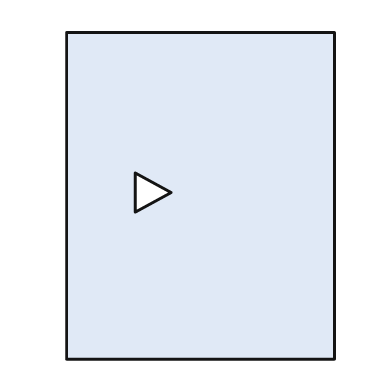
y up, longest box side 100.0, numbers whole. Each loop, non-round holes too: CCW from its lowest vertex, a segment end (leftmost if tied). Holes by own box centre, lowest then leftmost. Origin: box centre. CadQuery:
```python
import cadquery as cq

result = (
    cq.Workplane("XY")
    .moveTo(-41.0, -50.0)
    .lineTo(41.0, -50.0)
    .lineTo(41.0, 50.0)
    .lineTo(-41.0, 50.0)
    .close()
    .moveTo(-20.0, -5.0)
    .lineTo(-9.0, 1.0)
    .lineTo(-20.0, 7.0)
    .close()
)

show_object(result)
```